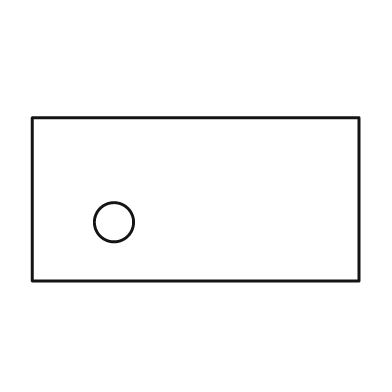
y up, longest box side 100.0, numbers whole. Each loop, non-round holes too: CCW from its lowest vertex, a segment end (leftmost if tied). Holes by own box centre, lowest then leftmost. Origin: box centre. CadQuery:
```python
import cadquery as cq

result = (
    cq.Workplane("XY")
    .moveTo(-50.0, -25.0)
    .lineTo(50.0, -25.0)
    .lineTo(50.0, 25.0)
    .lineTo(-50.0, 25.0)
    .close()
    .moveTo(-25.0, -7.0)
    .circle(6.0)
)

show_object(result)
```